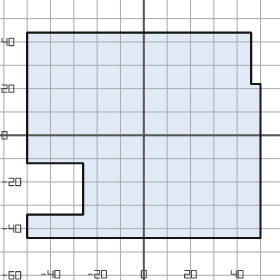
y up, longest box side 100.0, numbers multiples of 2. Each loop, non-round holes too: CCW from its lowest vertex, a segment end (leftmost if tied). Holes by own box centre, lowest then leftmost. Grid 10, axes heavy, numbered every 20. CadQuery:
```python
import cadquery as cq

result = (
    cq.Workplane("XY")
    .moveTo(-50.0, -44.0)
    .lineTo(50.0, -44.0)
    .lineTo(50.0, 22.0)
    .lineTo(46.0, 22.0)
    .lineTo(46.0, 44.0)
    .lineTo(-50.0, 44.0)
    .lineTo(-50.0, -12.0)
    .lineTo(-26.0, -12.0)
    .lineTo(-26.0, -34.0)
    .lineTo(-50.0, -34.0)
    .close()
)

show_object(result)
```